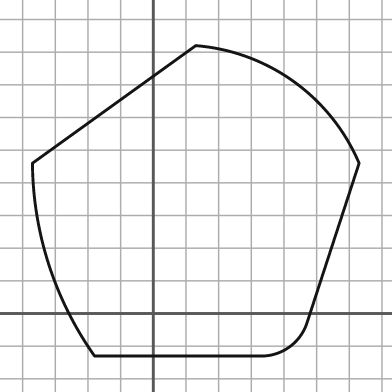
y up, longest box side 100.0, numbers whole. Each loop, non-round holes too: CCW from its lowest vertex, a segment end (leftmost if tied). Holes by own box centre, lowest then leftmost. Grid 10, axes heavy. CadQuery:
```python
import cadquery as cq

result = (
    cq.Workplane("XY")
    .moveTo(-18.0, -13.0)
    .lineTo(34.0, -13.0)
    .threePointArc((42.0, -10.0), (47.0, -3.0))
    .lineTo(63.0, 46.0)
    .threePointArc((43.0, 71.0), (13.0, 82.0))
    .lineTo(-37.0, 46.0)
    .threePointArc((-32.0, 15.0), (-18.0, -13.0))
    .close()
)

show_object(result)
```